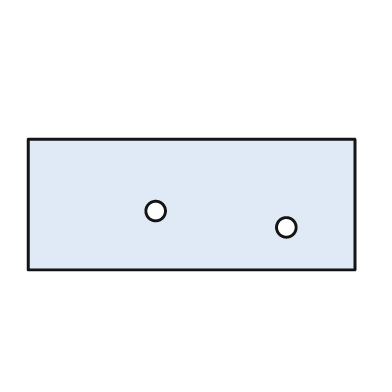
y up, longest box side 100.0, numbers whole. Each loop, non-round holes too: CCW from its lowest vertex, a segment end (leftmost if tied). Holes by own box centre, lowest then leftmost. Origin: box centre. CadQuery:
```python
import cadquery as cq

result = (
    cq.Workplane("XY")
    .moveTo(-50.0, -20.0)
    .lineTo(50.0, -20.0)
    .lineTo(50.0, 20.0)
    .lineTo(-50.0, 20.0)
    .close()
    .moveTo(29.0, -7.0)
    .circle(3.0)
    .moveTo(-11.0, -2.0)
    .circle(3.0)
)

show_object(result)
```